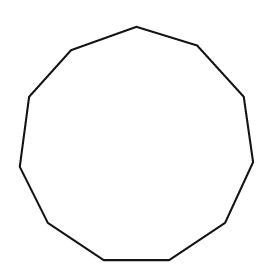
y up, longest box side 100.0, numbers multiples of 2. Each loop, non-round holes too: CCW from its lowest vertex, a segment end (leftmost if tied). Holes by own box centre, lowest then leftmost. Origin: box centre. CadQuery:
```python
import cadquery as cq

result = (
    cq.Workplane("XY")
    .moveTo(-14.0, -50.0)
    .lineTo(14.0, -50.0)
    .lineTo(38.0, -34.0)
    .lineTo(50.0, -8.0)
    .lineTo(46.0, 20.0)
    .lineTo(26.0, 42.0)
    .lineTo(0.0, 50.0)
    .lineTo(-28.0, 40.0)
    .lineTo(-46.0, 20.0)
    .lineTo(-50.0, -10.0)
    .lineTo(-38.0, -34.0)
    .close()
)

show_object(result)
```